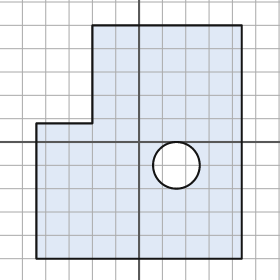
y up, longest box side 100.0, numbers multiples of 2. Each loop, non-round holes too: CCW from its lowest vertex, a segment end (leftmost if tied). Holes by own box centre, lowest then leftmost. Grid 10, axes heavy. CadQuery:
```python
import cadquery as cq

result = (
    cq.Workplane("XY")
    .moveTo(-44.0, -50.0)
    .lineTo(44.0, -50.0)
    .lineTo(44.0, 50.0)
    .lineTo(-20.0, 50.0)
    .lineTo(-20.0, 8.0)
    .lineTo(-44.0, 8.0)
    .close()
    .moveTo(16.0, -10.0)
    .circle(10.0)
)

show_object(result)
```